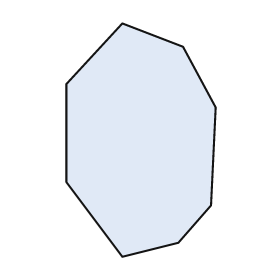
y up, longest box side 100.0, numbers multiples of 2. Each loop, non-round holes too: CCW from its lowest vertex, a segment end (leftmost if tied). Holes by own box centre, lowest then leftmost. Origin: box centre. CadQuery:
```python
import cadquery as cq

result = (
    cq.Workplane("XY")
    .moveTo(-8.0, -50.0)
    .lineTo(16.0, -44.0)
    .lineTo(30.0, -28.0)
    .lineTo(32.0, 14.0)
    .lineTo(18.0, 40.0)
    .lineTo(-8.0, 50.0)
    .lineTo(-32.0, 24.0)
    .lineTo(-32.0, -18.0)
    .close()
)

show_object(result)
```